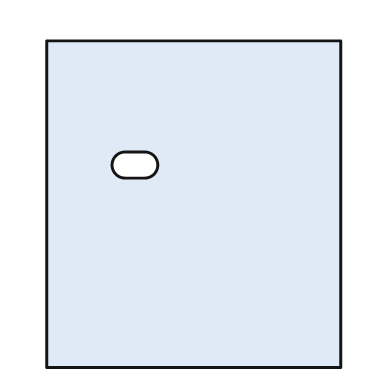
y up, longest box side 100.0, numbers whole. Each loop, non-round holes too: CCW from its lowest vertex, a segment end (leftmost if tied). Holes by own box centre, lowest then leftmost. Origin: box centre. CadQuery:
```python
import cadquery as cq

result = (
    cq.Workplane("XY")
    .moveTo(-45.0, -50.0)
    .lineTo(45.0, -50.0)
    .lineTo(45.0, 50.0)
    .lineTo(-45.0, 50.0)
    .close()
    .moveTo(-21.0, 8.0)
    .lineTo(-15.0, 8.0)
    .threePointArc((-11.0, 12.0), (-15.0, 16.0))
    .lineTo(-21.0, 16.0)
    .threePointArc((-25.0, 12.0), (-21.0, 8.0))
    .close()
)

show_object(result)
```